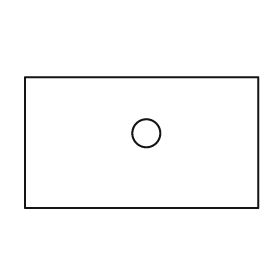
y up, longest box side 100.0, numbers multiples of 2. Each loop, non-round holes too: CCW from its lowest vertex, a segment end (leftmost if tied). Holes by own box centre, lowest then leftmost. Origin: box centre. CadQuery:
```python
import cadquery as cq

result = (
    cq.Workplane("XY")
    .moveTo(-50.0, -28.0)
    .lineTo(50.0, -28.0)
    .lineTo(50.0, 28.0)
    .lineTo(-50.0, 28.0)
    .close()
    .moveTo(2.0, 4.0)
    .circle(6.0)
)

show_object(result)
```